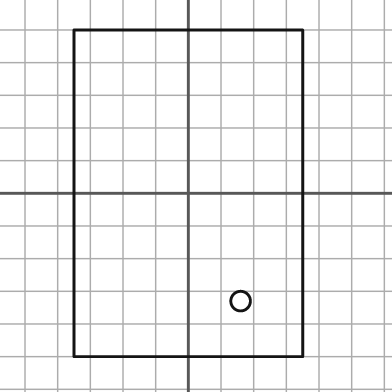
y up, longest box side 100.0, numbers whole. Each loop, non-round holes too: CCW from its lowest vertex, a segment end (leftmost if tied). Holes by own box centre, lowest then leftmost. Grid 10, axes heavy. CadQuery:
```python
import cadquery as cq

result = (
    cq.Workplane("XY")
    .moveTo(-35.0, -50.0)
    .lineTo(35.0, -50.0)
    .lineTo(35.0, 50.0)
    .lineTo(-35.0, 50.0)
    .close()
    .moveTo(16.0, -33.0)
    .circle(3.0)
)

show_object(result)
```